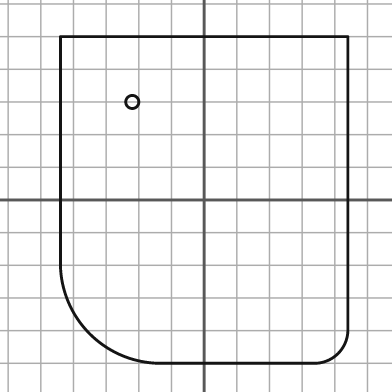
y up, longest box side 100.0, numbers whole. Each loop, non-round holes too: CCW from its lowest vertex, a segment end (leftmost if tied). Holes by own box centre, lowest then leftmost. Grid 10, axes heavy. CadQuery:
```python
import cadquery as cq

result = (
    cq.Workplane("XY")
    .moveTo(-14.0, -50.0)
    .lineTo(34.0, -50.0)
    .threePointArc((41.0, -47.0), (44.0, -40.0))
    .lineTo(44.0, 50.0)
    .lineTo(-44.0, 50.0)
    .lineTo(-44.0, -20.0)
    .threePointArc((-35.0, -41.0), (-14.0, -50.0))
    .close()
    .moveTo(-22.0, 30.0)
    .circle(2.0)
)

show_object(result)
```